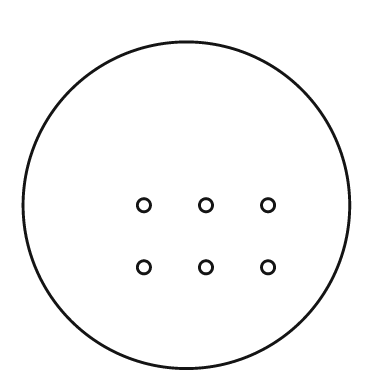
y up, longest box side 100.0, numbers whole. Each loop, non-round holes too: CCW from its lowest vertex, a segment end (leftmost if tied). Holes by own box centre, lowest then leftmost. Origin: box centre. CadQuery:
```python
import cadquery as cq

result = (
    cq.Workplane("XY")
    .moveTo(0.0, 0.0)
    .circle(50.0)
    .moveTo(-13.0, -19.0)
    .circle(2.0)
    .moveTo(6.0, -19.0)
    .circle(2.0)
    .moveTo(25.0, -19.0)
    .circle(2.0)
    .moveTo(-13.0, 0.0)
    .circle(2.0)
    .moveTo(6.0, 0.0)
    .circle(2.0)
    .moveTo(25.0, 0.0)
    .circle(2.0)
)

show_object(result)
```